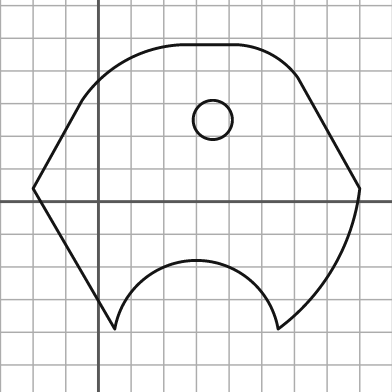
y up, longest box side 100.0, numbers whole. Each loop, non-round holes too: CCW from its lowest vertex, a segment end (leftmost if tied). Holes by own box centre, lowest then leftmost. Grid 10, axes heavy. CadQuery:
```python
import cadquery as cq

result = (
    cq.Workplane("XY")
    .moveTo(5.0, -39.0)
    .threePointArc((30.0, -18.0), (55.0, -39.0))
    .threePointArc((72.0, -20.0), (80.0, 4.0))
    .lineTo(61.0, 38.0)
    .threePointArc((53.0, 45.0), (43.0, 48.0))
    .lineTo(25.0, 48.0)
    .threePointArc((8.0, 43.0), (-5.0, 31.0))
    .lineTo(-20.0, 4.0)
    .close()
    .moveTo(35.0, 25.0)
    .circle(6.0)
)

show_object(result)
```